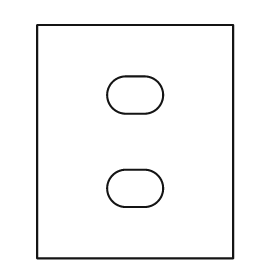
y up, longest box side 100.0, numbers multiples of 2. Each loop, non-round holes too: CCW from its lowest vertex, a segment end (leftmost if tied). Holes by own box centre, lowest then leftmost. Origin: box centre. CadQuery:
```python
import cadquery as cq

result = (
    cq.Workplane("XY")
    .moveTo(-42.0, -50.0)
    .lineTo(42.0, -50.0)
    .lineTo(42.0, 50.0)
    .lineTo(-42.0, 50.0)
    .close()
    .moveTo(-4.0, -28.0)
    .lineTo(4.0, -28.0)
    .threePointArc((12.0, -20.0), (4.0, -12.0))
    .lineTo(-4.0, -12.0)
    .threePointArc((-12.0, -20.0), (-4.0, -28.0))
    .close()
    .moveTo(-4.0, 12.0)
    .lineTo(4.0, 12.0)
    .threePointArc((12.0, 20.0), (4.0, 28.0))
    .lineTo(-4.0, 28.0)
    .threePointArc((-12.0, 20.0), (-4.0, 12.0))
    .close()
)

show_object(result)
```